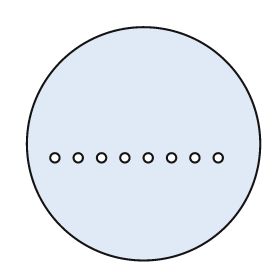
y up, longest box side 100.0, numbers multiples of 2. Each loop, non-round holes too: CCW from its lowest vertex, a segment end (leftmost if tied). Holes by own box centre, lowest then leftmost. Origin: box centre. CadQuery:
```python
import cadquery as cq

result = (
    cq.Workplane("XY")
    .moveTo(0.0, 0.0)
    .circle(50.0)
    .moveTo(-38.0, -6.0)
    .circle(2.0)
    .moveTo(-28.0, -6.0)
    .circle(2.0)
    .moveTo(-18.0, -6.0)
    .circle(2.0)
    .moveTo(-8.0, -6.0)
    .circle(2.0)
    .moveTo(2.0, -6.0)
    .circle(2.0)
    .moveTo(12.0, -6.0)
    .circle(2.0)
    .moveTo(22.0, -6.0)
    .circle(2.0)
    .moveTo(32.0, -6.0)
    .circle(2.0)
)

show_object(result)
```